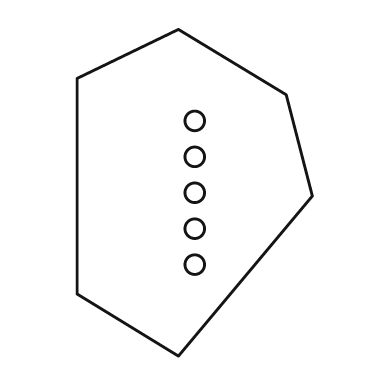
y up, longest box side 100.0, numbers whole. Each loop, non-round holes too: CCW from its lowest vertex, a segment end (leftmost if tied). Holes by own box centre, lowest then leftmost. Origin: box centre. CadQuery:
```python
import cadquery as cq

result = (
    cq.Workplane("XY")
    .moveTo(-5.0, -50.0)
    .lineTo(36.0, -1.0)
    .lineTo(28.0, 30.0)
    .lineTo(-5.0, 50.0)
    .lineTo(-36.0, 35.0)
    .lineTo(-36.0, -31.0)
    .close()
    .moveTo(0.0, -22.0)
    .circle(3.0)
    .moveTo(0.0, -11.0)
    .circle(3.0)
    .moveTo(0.0, 0.0)
    .circle(3.0)
    .moveTo(0.0, 11.0)
    .circle(3.0)
    .moveTo(0.0, 22.0)
    .circle(3.0)
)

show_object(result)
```